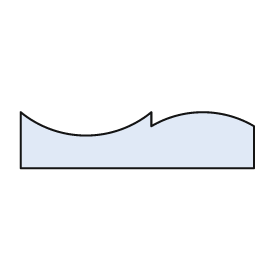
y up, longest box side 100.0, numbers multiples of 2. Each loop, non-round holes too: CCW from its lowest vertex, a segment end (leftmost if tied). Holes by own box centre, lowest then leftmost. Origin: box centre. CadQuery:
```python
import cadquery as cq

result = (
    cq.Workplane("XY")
    .moveTo(-50.0, -12.0)
    .lineTo(50.0, -12.0)
    .lineTo(50.0, 6.0)
    .threePointArc((28.0, 12.0), (6.0, 6.0))
    .lineTo(6.0, 12.0)
    .threePointArc((-22.0, 2.0), (-50.0, 12.0))
    .close()
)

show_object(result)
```